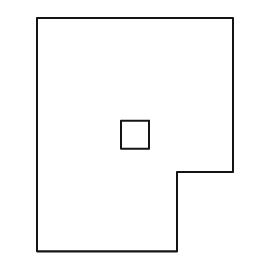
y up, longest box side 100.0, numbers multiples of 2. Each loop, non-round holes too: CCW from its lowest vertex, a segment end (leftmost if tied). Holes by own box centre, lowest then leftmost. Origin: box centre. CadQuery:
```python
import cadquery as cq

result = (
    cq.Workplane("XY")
    .moveTo(-42.0, -50.0)
    .lineTo(18.0, -50.0)
    .lineTo(18.0, -16.0)
    .lineTo(42.0, -16.0)
    .lineTo(42.0, 50.0)
    .lineTo(-42.0, 50.0)
    .close()
    .moveTo(-6.0, -6.0)
    .lineTo(6.0, -6.0)
    .lineTo(6.0, 6.0)
    .lineTo(-6.0, 6.0)
    .close()
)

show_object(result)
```